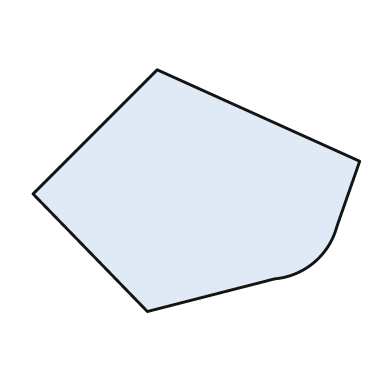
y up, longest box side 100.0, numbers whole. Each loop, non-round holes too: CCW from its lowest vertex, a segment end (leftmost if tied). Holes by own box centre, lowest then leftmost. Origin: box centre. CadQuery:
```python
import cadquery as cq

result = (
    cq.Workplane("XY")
    .moveTo(-15.0, -37.0)
    .lineTo(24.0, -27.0)
    .threePointArc((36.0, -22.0), (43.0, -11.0))
    .lineTo(50.0, 9.0)
    .lineTo(-12.0, 37.0)
    .lineTo(-50.0, -1.0)
    .close()
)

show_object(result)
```